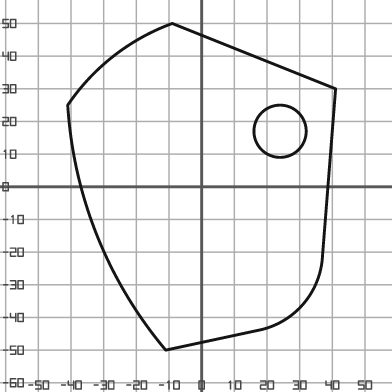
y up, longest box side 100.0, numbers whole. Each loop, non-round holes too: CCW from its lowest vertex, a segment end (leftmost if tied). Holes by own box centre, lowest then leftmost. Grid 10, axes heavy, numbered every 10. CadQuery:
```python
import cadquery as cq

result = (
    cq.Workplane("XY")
    .moveTo(-11.0, -50.0)
    .lineTo(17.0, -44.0)
    .threePointArc((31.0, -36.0), (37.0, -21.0))
    .lineTo(41.0, 30.0)
    .lineTo(-9.0, 50.0)
    .threePointArc((-27.0, 40.0), (-41.0, 25.0))
    .threePointArc((-32.0, -15.0), (-11.0, -50.0))
    .close()
    .moveTo(24.0, 17.0)
    .circle(8.0)
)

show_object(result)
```